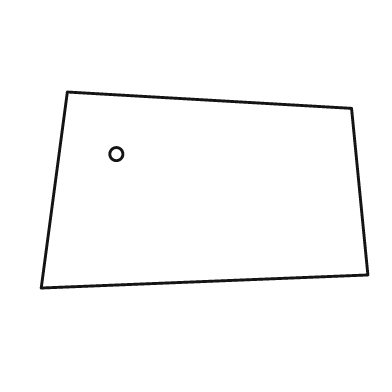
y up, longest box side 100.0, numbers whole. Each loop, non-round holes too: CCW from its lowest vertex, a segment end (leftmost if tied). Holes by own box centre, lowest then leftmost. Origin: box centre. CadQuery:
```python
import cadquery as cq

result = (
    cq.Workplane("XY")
    .moveTo(-50.0, -30.0)
    .lineTo(50.0, -26.0)
    .lineTo(45.0, 25.0)
    .lineTo(-42.0, 30.0)
    .close()
    .moveTo(-27.0, 11.0)
    .circle(2.0)
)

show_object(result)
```